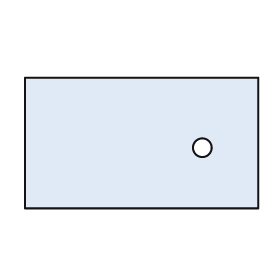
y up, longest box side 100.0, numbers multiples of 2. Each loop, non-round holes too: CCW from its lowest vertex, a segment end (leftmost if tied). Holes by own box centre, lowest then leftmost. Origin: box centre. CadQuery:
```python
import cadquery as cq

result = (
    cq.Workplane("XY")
    .moveTo(-50.0, -28.0)
    .lineTo(50.0, -28.0)
    .lineTo(50.0, 28.0)
    .lineTo(-50.0, 28.0)
    .close()
    .moveTo(26.0, -2.0)
    .circle(4.0)
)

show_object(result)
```